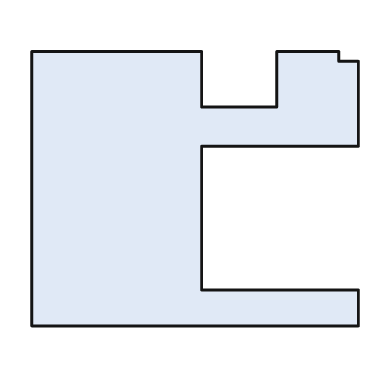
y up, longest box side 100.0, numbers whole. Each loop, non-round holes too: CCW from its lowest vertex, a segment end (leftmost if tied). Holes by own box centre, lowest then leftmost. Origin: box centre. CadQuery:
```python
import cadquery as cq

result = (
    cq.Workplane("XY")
    .moveTo(-50.0, -42.0)
    .lineTo(50.0, -42.0)
    .lineTo(50.0, -31.0)
    .lineTo(2.0, -31.0)
    .lineTo(2.0, 13.0)
    .lineTo(50.0, 13.0)
    .lineTo(50.0, 39.0)
    .lineTo(44.0, 39.0)
    .lineTo(44.0, 42.0)
    .lineTo(25.0, 42.0)
    .lineTo(25.0, 25.0)
    .lineTo(2.0, 25.0)
    .lineTo(2.0, 42.0)
    .lineTo(-50.0, 42.0)
    .close()
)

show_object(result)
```